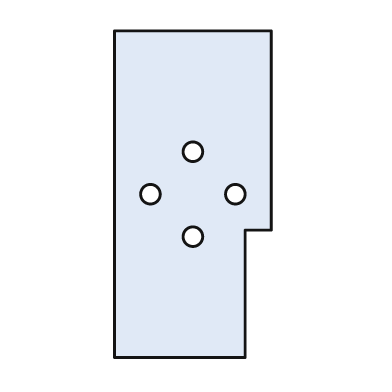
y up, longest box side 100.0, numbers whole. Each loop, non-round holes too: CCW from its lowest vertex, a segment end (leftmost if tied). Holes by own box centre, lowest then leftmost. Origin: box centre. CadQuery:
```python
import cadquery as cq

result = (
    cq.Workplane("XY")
    .moveTo(-24.0, -50.0)
    .lineTo(16.0, -50.0)
    .lineTo(16.0, -11.0)
    .lineTo(24.0, -11.0)
    .lineTo(24.0, 50.0)
    .lineTo(-24.0, 50.0)
    .close()
    .moveTo(0.0, -13.0)
    .circle(3.0)
    .moveTo(-13.0, 0.0)
    .circle(3.0)
    .moveTo(13.0, 0.0)
    .circle(3.0)
    .moveTo(0.0, 13.0)
    .circle(3.0)
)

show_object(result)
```